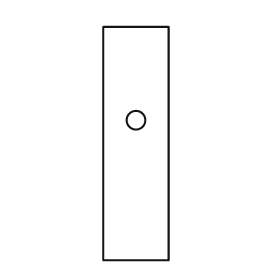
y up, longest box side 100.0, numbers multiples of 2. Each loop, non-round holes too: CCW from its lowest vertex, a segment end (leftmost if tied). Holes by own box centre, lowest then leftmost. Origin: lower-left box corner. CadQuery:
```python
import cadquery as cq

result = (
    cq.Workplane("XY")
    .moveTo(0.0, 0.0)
    .lineTo(28.0, 0.0)
    .lineTo(28.0, 100.0)
    .lineTo(0.0, 100.0)
    .close()
    .moveTo(14.0, 60.0)
    .circle(4.0)
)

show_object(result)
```